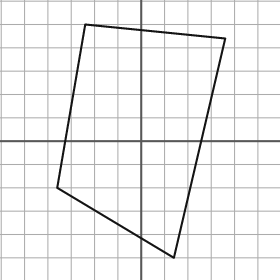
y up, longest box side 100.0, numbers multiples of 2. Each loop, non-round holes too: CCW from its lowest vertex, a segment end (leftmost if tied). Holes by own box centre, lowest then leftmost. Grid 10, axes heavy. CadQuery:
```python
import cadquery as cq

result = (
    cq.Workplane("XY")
    .moveTo(14.0, -50.0)
    .lineTo(36.0, 44.0)
    .lineTo(-24.0, 50.0)
    .lineTo(-36.0, -20.0)
    .close()
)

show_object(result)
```